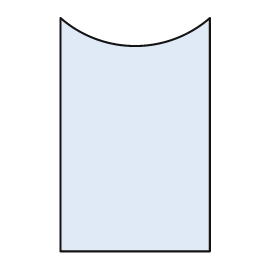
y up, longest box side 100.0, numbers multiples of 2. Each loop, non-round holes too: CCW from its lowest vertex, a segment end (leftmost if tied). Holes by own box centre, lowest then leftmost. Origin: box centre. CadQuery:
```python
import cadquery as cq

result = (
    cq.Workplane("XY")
    .moveTo(-32.0, -50.0)
    .lineTo(32.0, -50.0)
    .lineTo(32.0, 50.0)
    .threePointArc((0.0, 38.0), (-32.0, 50.0))
    .close()
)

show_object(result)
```